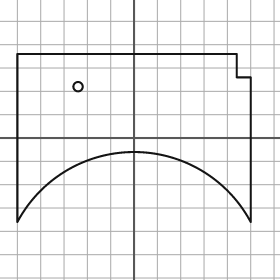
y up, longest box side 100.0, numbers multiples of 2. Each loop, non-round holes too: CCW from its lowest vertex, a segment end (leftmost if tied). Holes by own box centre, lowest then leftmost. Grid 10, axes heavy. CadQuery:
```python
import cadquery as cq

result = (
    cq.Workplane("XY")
    .moveTo(-50.0, -36.0)
    .threePointArc((0.0, -6.0), (50.0, -36.0))
    .lineTo(50.0, 26.0)
    .lineTo(44.0, 26.0)
    .lineTo(44.0, 36.0)
    .lineTo(-50.0, 36.0)
    .close()
    .moveTo(-24.0, 22.0)
    .circle(2.0)
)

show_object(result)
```